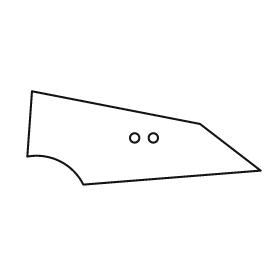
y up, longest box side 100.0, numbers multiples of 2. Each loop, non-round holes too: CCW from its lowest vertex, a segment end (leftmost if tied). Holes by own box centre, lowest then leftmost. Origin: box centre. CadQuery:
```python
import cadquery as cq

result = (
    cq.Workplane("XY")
    .moveTo(-26.0, -20.0)
    .lineTo(50.0, -14.0)
    .lineTo(24.0, 6.0)
    .lineTo(-48.0, 20.0)
    .lineTo(-50.0, -8.0)
    .threePointArc((-36.0, -10.0), (-26.0, -20.0))
    .close()
    .moveTo(-4.0, 0.0)
    .circle(2.0)
    .moveTo(4.0, 0.0)
    .circle(2.0)
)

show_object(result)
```